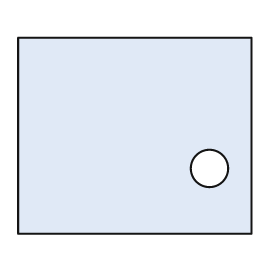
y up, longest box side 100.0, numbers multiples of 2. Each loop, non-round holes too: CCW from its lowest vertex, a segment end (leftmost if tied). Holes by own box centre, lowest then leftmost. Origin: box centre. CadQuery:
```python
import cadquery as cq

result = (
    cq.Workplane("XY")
    .moveTo(-50.0, -42.0)
    .lineTo(50.0, -42.0)
    .lineTo(50.0, 42.0)
    .lineTo(-50.0, 42.0)
    .close()
    .moveTo(32.0, -14.0)
    .circle(8.0)
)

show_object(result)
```